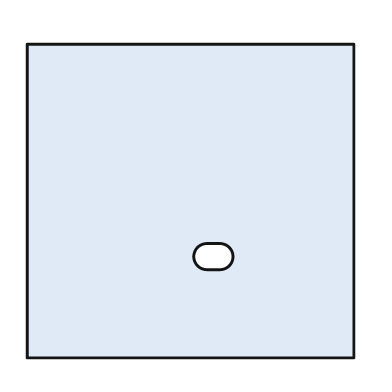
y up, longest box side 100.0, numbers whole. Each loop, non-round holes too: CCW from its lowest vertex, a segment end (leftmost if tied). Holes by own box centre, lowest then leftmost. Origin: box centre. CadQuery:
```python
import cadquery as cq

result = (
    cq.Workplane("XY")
    .moveTo(-50.0, -48.0)
    .lineTo(50.0, -48.0)
    .lineTo(50.0, 48.0)
    .lineTo(-50.0, 48.0)
    .close()
    .moveTo(5.0, -21.0)
    .lineTo(9.0, -21.0)
    .threePointArc((13.0, -17.0), (9.0, -13.0))
    .lineTo(5.0, -13.0)
    .threePointArc((1.0, -17.0), (5.0, -21.0))
    .close()
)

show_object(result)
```